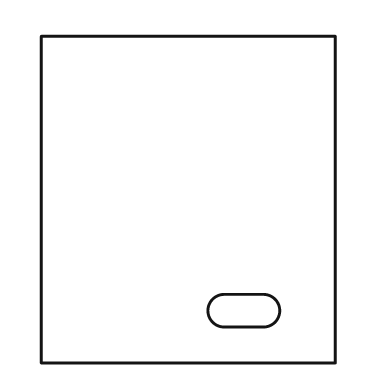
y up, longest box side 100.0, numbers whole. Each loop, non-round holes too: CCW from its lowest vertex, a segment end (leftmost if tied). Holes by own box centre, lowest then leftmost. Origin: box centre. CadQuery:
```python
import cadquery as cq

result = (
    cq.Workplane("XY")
    .moveTo(-45.0, -50.0)
    .lineTo(45.0, -50.0)
    .lineTo(45.0, 50.0)
    .lineTo(-45.0, 50.0)
    .close()
    .moveTo(11.0, -39.0)
    .lineTo(23.0, -39.0)
    .threePointArc((28.0, -34.0), (23.0, -29.0))
    .lineTo(11.0, -29.0)
    .threePointArc((6.0, -34.0), (11.0, -39.0))
    .close()
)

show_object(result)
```